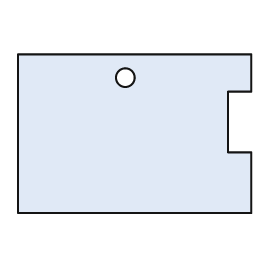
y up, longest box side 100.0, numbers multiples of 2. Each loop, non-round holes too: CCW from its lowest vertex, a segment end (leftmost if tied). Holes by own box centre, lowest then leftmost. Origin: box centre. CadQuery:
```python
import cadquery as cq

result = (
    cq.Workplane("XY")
    .moveTo(-50.0, -34.0)
    .lineTo(50.0, -34.0)
    .lineTo(50.0, -8.0)
    .lineTo(40.0, -8.0)
    .lineTo(40.0, 18.0)
    .lineTo(50.0, 18.0)
    .lineTo(50.0, 34.0)
    .lineTo(-50.0, 34.0)
    .close()
    .moveTo(-4.0, 24.0)
    .circle(4.0)
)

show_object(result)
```